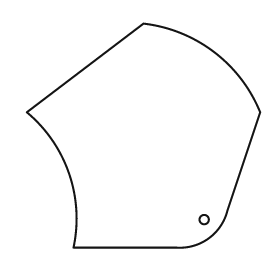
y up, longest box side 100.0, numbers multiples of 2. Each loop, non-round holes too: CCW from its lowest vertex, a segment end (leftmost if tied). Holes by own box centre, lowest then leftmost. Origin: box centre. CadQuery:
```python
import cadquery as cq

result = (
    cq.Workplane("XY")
    .moveTo(-30.0, -48.0)
    .lineTo(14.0, -48.0)
    .threePointArc((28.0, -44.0), (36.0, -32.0))
    .lineTo(50.0, 10.0)
    .threePointArc((30.0, 36.0), (0.0, 48.0))
    .lineTo(-50.0, 10.0)
    .threePointArc((-32.0, -16.0), (-30.0, -48.0))
    .close()
    .moveTo(26.0, -36.0)
    .circle(2.0)
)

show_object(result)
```